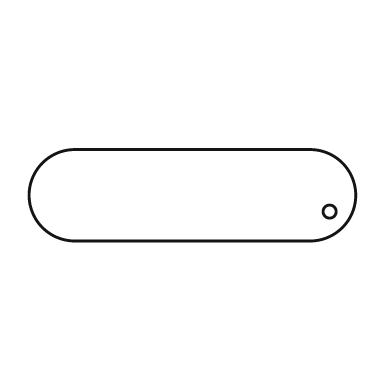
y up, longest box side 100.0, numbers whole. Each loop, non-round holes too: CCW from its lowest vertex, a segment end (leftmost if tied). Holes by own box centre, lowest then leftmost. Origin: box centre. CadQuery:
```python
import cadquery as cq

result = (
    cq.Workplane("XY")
    .moveTo(-36.0, -14.0)
    .lineTo(36.0, -14.0)
    .threePointArc((50.0, 0.0), (36.0, 14.0))
    .lineTo(-36.0, 14.0)
    .threePointArc((-50.0, 0.0), (-36.0, -14.0))
    .close()
    .moveTo(42.0, -5.0)
    .circle(2.0)
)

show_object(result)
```